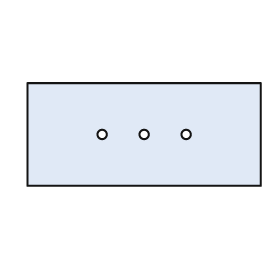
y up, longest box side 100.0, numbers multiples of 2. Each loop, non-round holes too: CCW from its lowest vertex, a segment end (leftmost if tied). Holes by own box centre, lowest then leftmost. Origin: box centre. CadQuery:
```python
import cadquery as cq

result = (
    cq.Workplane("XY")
    .moveTo(-50.0, -22.0)
    .lineTo(50.0, -22.0)
    .lineTo(50.0, 22.0)
    .lineTo(-50.0, 22.0)
    .close()
    .moveTo(-18.0, 0.0)
    .circle(2.0)
    .moveTo(0.0, 0.0)
    .circle(2.0)
    .moveTo(18.0, 0.0)
    .circle(2.0)
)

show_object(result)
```